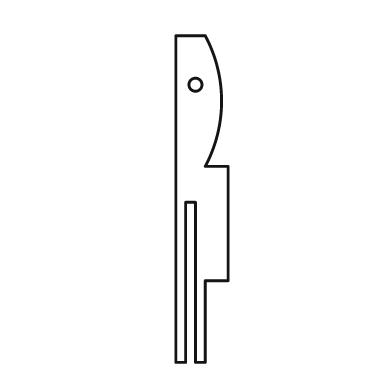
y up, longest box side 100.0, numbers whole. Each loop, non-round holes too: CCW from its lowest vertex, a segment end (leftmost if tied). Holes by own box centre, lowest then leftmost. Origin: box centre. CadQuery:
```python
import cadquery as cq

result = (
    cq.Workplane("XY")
    .moveTo(-8.0, -50.0)
    .lineTo(-5.0, -50.0)
    .lineTo(-5.0, -1.0)
    .lineTo(-2.0, -1.0)
    .lineTo(-2.0, -50.0)
    .lineTo(1.0, -50.0)
    .lineTo(1.0, -25.0)
    .lineTo(8.0, -25.0)
    .lineTo(8.0, 10.0)
    .lineTo(1.0, 10.0)
    .threePointArc((6.0, 30.0), (1.0, 50.0))
    .lineTo(-8.0, 50.0)
    .close()
    .moveTo(-2.0, 35.0)
    .circle(2.0)
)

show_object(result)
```